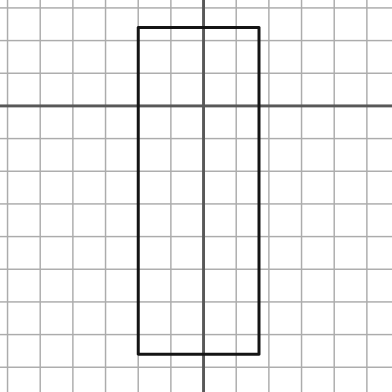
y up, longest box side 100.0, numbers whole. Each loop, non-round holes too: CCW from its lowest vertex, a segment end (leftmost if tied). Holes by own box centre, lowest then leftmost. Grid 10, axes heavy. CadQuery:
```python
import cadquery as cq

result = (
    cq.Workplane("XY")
    .moveTo(-20.0, -76.0)
    .lineTo(17.0, -76.0)
    .lineTo(17.0, 24.0)
    .lineTo(-20.0, 24.0)
    .close()
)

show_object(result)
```